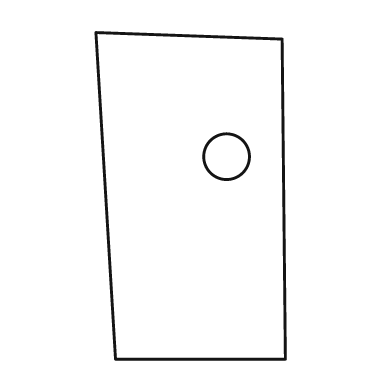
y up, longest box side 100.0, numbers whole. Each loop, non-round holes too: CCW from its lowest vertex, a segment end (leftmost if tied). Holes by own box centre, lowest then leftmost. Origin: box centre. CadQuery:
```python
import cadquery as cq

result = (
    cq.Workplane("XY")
    .moveTo(-23.0, -50.0)
    .lineTo(29.0, -50.0)
    .lineTo(28.0, 48.0)
    .lineTo(-29.0, 50.0)
    .close()
    .moveTo(11.0, 12.0)
    .circle(7.0)
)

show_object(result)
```